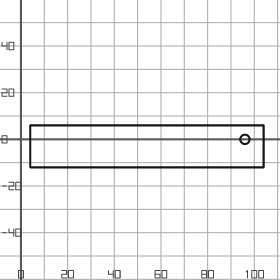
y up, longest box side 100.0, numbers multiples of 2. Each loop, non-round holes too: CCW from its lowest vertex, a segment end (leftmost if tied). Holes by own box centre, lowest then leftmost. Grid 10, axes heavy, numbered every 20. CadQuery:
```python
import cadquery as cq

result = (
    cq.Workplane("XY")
    .moveTo(4.0, -12.0)
    .lineTo(104.0, -12.0)
    .lineTo(104.0, 6.0)
    .lineTo(4.0, 6.0)
    .close()
    .moveTo(96.0, 0.0)
    .circle(2.0)
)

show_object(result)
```